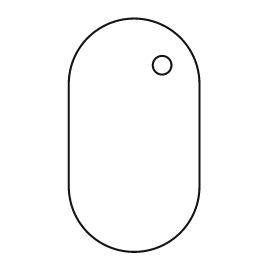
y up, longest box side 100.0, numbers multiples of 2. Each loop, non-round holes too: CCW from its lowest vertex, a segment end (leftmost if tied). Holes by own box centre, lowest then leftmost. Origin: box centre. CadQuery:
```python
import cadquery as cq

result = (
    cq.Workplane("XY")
    .moveTo(-28.0, -22.0)
    .threePointArc((0.0, -50.0), (28.0, -22.0))
    .lineTo(28.0, 22.0)
    .threePointArc((0.0, 50.0), (-28.0, 22.0))
    .close()
    .moveTo(12.0, 30.0)
    .circle(4.0)
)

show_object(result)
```